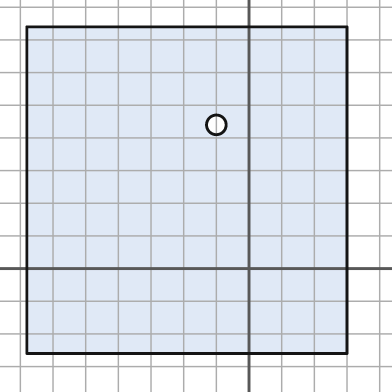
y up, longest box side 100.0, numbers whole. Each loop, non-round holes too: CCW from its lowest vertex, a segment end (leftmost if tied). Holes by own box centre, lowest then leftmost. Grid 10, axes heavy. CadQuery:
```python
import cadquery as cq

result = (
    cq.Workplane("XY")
    .moveTo(-68.0, -26.0)
    .lineTo(30.0, -26.0)
    .lineTo(30.0, 74.0)
    .lineTo(-68.0, 74.0)
    .close()
    .moveTo(-10.0, 44.0)
    .circle(3.0)
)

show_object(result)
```